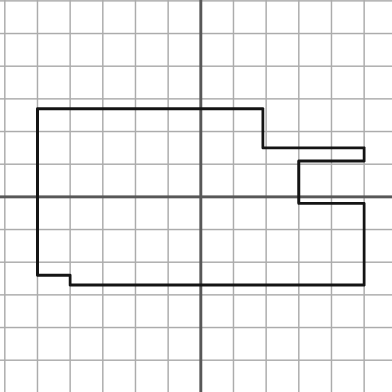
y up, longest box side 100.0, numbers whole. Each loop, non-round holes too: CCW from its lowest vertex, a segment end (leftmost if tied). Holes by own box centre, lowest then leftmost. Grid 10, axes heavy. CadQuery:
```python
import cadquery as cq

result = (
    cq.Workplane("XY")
    .moveTo(-40.0, -27.0)
    .lineTo(50.0, -27.0)
    .lineTo(50.0, -2.0)
    .lineTo(30.0, -2.0)
    .lineTo(30.0, 11.0)
    .lineTo(50.0, 11.0)
    .lineTo(50.0, 15.0)
    .lineTo(19.0, 15.0)
    .lineTo(19.0, 27.0)
    .lineTo(-50.0, 27.0)
    .lineTo(-50.0, -24.0)
    .lineTo(-40.0, -24.0)
    .close()
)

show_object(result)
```